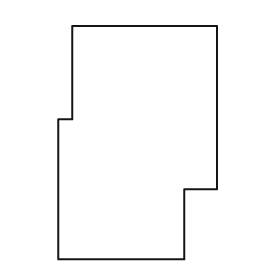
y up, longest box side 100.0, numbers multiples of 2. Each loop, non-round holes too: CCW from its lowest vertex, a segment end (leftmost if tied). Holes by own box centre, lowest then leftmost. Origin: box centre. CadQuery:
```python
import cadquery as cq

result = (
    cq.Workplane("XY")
    .moveTo(-34.0, -50.0)
    .lineTo(20.0, -50.0)
    .lineTo(20.0, -20.0)
    .lineTo(34.0, -20.0)
    .lineTo(34.0, 50.0)
    .lineTo(-28.0, 50.0)
    .lineTo(-28.0, 10.0)
    .lineTo(-34.0, 10.0)
    .close()
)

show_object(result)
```